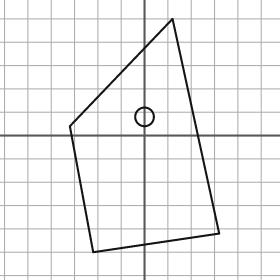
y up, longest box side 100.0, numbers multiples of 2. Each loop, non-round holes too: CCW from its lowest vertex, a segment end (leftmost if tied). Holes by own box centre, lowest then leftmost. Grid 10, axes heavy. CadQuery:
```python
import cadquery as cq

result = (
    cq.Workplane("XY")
    .moveTo(-22.0, -50.0)
    .lineTo(32.0, -42.0)
    .lineTo(12.0, 50.0)
    .lineTo(-32.0, 4.0)
    .close()
    .moveTo(0.0, 8.0)
    .circle(4.0)
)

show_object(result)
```